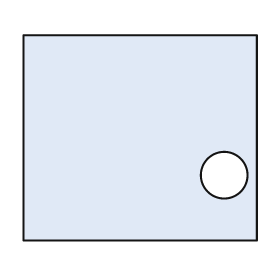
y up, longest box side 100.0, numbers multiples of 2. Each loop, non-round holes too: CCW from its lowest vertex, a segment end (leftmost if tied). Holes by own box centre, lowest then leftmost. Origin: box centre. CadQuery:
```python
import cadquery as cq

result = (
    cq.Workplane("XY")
    .moveTo(-50.0, -44.0)
    .lineTo(50.0, -44.0)
    .lineTo(50.0, 44.0)
    .lineTo(-50.0, 44.0)
    .close()
    .moveTo(36.0, -16.0)
    .circle(10.0)
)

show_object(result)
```